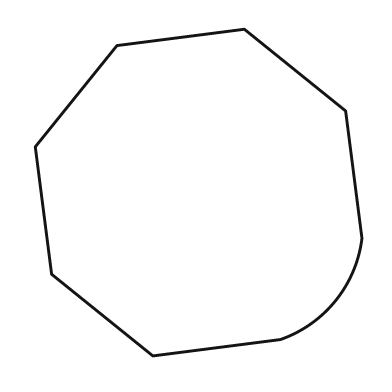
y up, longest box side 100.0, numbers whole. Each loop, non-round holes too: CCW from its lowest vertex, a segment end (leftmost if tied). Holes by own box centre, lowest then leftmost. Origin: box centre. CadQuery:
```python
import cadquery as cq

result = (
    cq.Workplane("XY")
    .moveTo(-14.0, -50.0)
    .lineTo(25.0, -45.0)
    .threePointArc((42.0, -33.0), (50.0, -14.0))
    .lineTo(45.0, 25.0)
    .lineTo(14.0, 50.0)
    .lineTo(-25.0, 45.0)
    .lineTo(-50.0, 14.0)
    .lineTo(-45.0, -25.0)
    .close()
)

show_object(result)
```